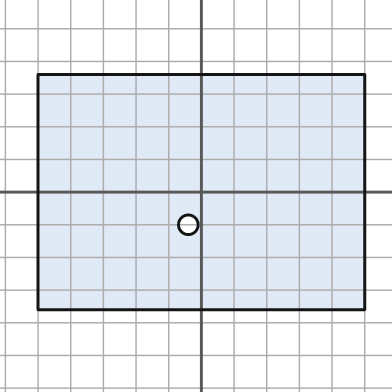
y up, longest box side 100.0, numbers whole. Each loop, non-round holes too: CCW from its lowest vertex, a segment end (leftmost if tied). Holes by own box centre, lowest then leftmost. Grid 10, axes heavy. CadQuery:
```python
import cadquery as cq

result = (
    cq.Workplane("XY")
    .moveTo(-50.0, -36.0)
    .lineTo(50.0, -36.0)
    .lineTo(50.0, 36.0)
    .lineTo(-50.0, 36.0)
    .close()
    .moveTo(-4.0, -10.0)
    .circle(3.0)
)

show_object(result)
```